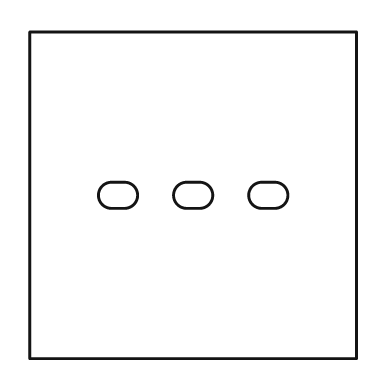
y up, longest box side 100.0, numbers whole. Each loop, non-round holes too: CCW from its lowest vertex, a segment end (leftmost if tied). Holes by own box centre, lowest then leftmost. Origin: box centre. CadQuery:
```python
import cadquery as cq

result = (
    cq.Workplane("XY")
    .moveTo(-50.0, -50.0)
    .lineTo(50.0, -50.0)
    .lineTo(50.0, 50.0)
    .lineTo(-50.0, 50.0)
    .close()
    .moveTo(-25.0, -4.0)
    .lineTo(-21.0, -4.0)
    .threePointArc((-17.0, 0.0), (-21.0, 4.0))
    .lineTo(-25.0, 4.0)
    .threePointArc((-29.0, 0.0), (-25.0, -4.0))
    .close()
    .moveTo(-2.0, -4.0)
    .lineTo(2.0, -4.0)
    .threePointArc((6.0, 0.0), (2.0, 4.0))
    .lineTo(-2.0, 4.0)
    .threePointArc((-6.0, 0.0), (-2.0, -4.0))
    .close()
    .moveTo(21.0, -4.0)
    .lineTo(25.0, -4.0)
    .threePointArc((29.0, 0.0), (25.0, 4.0))
    .lineTo(21.0, 4.0)
    .threePointArc((17.0, 0.0), (21.0, -4.0))
    .close()
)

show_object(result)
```